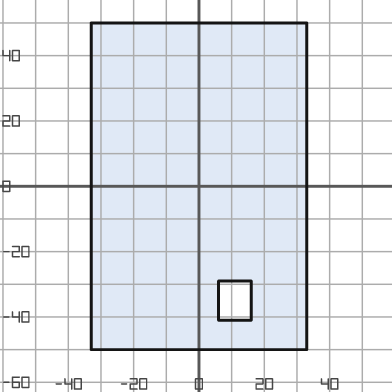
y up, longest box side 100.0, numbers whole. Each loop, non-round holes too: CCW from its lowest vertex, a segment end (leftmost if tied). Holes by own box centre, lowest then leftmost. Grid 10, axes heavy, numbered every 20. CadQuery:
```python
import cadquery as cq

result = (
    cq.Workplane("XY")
    .moveTo(-33.0, -50.0)
    .lineTo(33.0, -50.0)
    .lineTo(33.0, 50.0)
    .lineTo(-33.0, 50.0)
    .close()
    .moveTo(6.0, -41.0)
    .lineTo(16.0, -41.0)
    .lineTo(16.0, -29.0)
    .lineTo(6.0, -29.0)
    .close()
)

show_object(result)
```